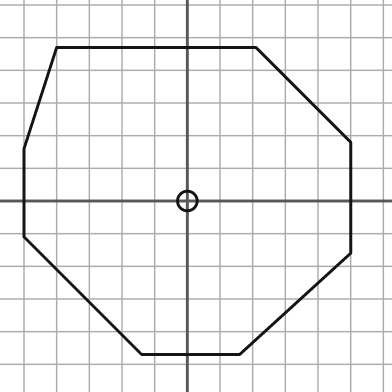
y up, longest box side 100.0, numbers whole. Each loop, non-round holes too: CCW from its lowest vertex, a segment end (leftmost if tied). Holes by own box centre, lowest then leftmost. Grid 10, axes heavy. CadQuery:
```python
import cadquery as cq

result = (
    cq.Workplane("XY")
    .moveTo(-14.0, -47.0)
    .lineTo(16.0, -47.0)
    .lineTo(50.0, -16.0)
    .lineTo(50.0, 18.0)
    .lineTo(21.0, 47.0)
    .lineTo(-40.0, 47.0)
    .lineTo(-50.0, 16.0)
    .lineTo(-50.0, -11.0)
    .close()
    .moveTo(0.0, 0.0)
    .circle(3.0)
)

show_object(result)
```